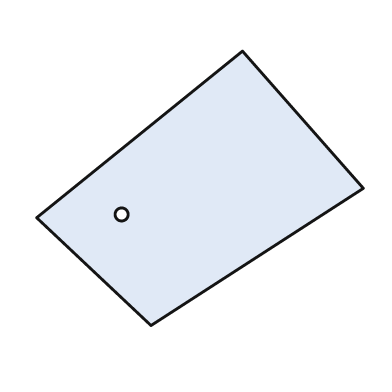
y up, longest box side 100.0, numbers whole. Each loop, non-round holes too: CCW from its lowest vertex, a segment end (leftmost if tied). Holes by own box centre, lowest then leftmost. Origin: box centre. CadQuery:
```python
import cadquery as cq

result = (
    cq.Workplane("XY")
    .moveTo(-15.0, -42.0)
    .lineTo(50.0, 0.0)
    .lineTo(13.0, 42.0)
    .lineTo(-50.0, -9.0)
    .close()
    .moveTo(-24.0, -8.0)
    .circle(2.0)
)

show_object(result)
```